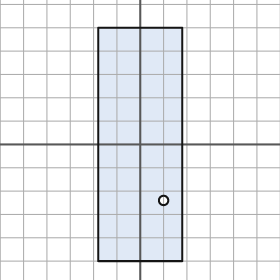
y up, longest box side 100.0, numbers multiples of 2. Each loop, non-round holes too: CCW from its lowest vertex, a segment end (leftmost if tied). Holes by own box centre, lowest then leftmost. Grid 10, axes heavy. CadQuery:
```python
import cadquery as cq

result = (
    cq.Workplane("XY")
    .moveTo(-18.0, -50.0)
    .lineTo(18.0, -50.0)
    .lineTo(18.0, 50.0)
    .lineTo(-18.0, 50.0)
    .close()
    .moveTo(10.0, -24.0)
    .circle(2.0)
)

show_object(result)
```